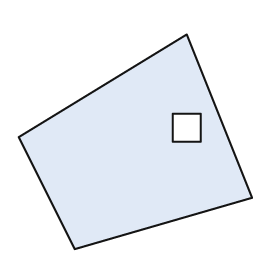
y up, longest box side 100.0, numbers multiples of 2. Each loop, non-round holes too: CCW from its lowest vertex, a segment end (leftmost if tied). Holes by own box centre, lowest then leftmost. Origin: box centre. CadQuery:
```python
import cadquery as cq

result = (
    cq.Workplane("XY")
    .moveTo(-26.0, -46.0)
    .lineTo(50.0, -24.0)
    .lineTo(22.0, 46.0)
    .lineTo(-50.0, 2.0)
    .close()
    .moveTo(16.0, 0.0)
    .lineTo(28.0, 0.0)
    .lineTo(28.0, 12.0)
    .lineTo(16.0, 12.0)
    .close()
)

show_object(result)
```